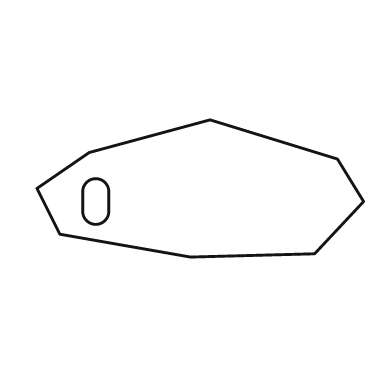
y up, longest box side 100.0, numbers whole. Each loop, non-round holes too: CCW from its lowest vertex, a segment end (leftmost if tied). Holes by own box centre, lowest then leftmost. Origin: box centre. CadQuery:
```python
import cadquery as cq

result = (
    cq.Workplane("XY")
    .moveTo(-3.0, -21.0)
    .lineTo(35.0, -20.0)
    .lineTo(50.0, -4.0)
    .lineTo(42.0, 9.0)
    .lineTo(3.0, 21.0)
    .lineTo(-34.0, 11.0)
    .lineTo(-50.0, 0.0)
    .lineTo(-43.0, -14.0)
    .close()
    .moveTo(-36.0, -7.0)
    .threePointArc((-32.0, -11.0), (-28.0, -7.0))
    .lineTo(-28.0, -1.0)
    .threePointArc((-32.0, 3.0), (-36.0, -1.0))
    .close()
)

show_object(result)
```